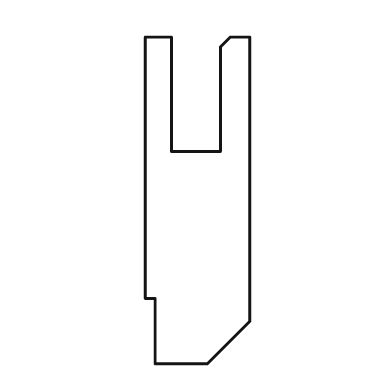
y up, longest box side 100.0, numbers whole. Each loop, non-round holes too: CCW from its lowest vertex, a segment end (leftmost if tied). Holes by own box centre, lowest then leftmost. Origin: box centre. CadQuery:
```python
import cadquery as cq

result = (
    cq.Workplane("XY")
    .moveTo(-13.0, -50.0)
    .lineTo(3.0, -50.0)
    .lineTo(16.0, -37.0)
    .lineTo(16.0, 50.0)
    .lineTo(10.0, 50.0)
    .lineTo(7.0, 47.0)
    .lineTo(7.0, 15.0)
    .lineTo(-8.0, 15.0)
    .lineTo(-8.0, 50.0)
    .lineTo(-16.0, 50.0)
    .lineTo(-16.0, -30.0)
    .lineTo(-13.0, -30.0)
    .close()
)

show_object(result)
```